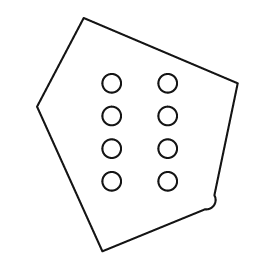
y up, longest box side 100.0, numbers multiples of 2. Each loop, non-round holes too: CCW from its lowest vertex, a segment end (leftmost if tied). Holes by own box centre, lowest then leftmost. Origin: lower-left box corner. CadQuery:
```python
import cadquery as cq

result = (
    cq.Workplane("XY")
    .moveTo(28.0, 0.0)
    .lineTo(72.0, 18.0)
    .threePointArc((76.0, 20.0), (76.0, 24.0))
    .lineTo(86.0, 72.0)
    .lineTo(20.0, 100.0)
    .lineTo(0.0, 62.0)
    .close()
    .moveTo(32.0, 30.0)
    .circle(4.0)
    .moveTo(56.0, 30.0)
    .circle(4.0)
    .moveTo(32.0, 44.0)
    .circle(4.0)
    .moveTo(56.0, 44.0)
    .circle(4.0)
    .moveTo(32.0, 58.0)
    .circle(4.0)
    .moveTo(56.0, 58.0)
    .circle(4.0)
    .moveTo(32.0, 72.0)
    .circle(4.0)
    .moveTo(56.0, 72.0)
    .circle(4.0)
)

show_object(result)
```